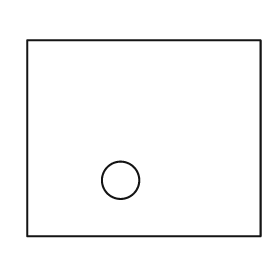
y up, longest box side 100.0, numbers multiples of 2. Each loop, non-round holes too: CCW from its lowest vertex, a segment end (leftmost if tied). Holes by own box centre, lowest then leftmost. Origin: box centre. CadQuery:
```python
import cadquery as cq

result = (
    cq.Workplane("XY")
    .moveTo(-50.0, -42.0)
    .lineTo(50.0, -42.0)
    .lineTo(50.0, 42.0)
    .lineTo(-50.0, 42.0)
    .close()
    .moveTo(-10.0, -18.0)
    .circle(8.0)
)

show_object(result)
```